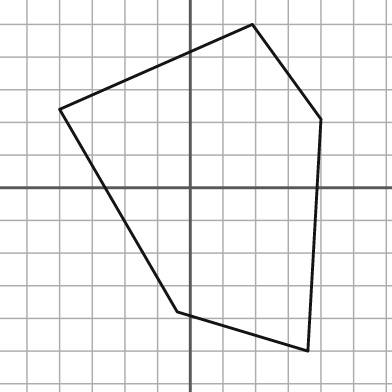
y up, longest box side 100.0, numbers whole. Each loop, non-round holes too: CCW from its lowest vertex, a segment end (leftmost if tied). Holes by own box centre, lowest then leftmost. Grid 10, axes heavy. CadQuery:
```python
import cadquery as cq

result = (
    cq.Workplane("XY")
    .moveTo(36.0, -50.0)
    .lineTo(40.0, 21.0)
    .lineTo(19.0, 50.0)
    .lineTo(-40.0, 24.0)
    .lineTo(-4.0, -38.0)
    .close()
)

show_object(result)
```